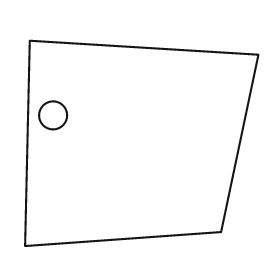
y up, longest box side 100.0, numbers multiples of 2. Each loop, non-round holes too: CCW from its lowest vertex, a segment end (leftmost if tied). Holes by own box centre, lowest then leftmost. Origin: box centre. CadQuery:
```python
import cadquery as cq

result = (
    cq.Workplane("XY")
    .moveTo(-50.0, -44.0)
    .lineTo(34.0, -38.0)
    .lineTo(50.0, 38.0)
    .lineTo(-48.0, 44.0)
    .close()
    .moveTo(-38.0, 12.0)
    .circle(6.0)
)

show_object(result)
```